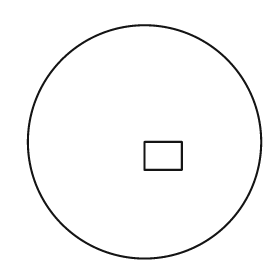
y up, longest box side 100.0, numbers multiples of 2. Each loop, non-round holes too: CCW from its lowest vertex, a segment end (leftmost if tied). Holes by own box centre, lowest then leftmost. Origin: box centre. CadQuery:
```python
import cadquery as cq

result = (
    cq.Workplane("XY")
    .moveTo(0.0, 0.0)
    .circle(50.0)
    .moveTo(0.0, -12.0)
    .lineTo(16.0, -12.0)
    .lineTo(16.0, 0.0)
    .lineTo(0.0, 0.0)
    .close()
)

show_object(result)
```